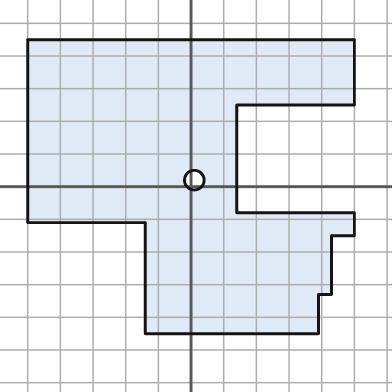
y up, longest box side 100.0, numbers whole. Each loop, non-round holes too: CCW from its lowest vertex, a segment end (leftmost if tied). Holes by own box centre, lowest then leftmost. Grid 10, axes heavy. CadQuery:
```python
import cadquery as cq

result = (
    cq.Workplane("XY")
    .moveTo(-14.0, -45.0)
    .lineTo(39.0, -45.0)
    .lineTo(39.0, -33.0)
    .lineTo(43.0, -33.0)
    .lineTo(43.0, -15.0)
    .lineTo(50.0, -15.0)
    .lineTo(50.0, -8.0)
    .lineTo(14.0, -8.0)
    .lineTo(14.0, 25.0)
    .lineTo(50.0, 25.0)
    .lineTo(50.0, 45.0)
    .lineTo(-50.0, 45.0)
    .lineTo(-50.0, -11.0)
    .lineTo(-14.0, -11.0)
    .close()
    .moveTo(1.0, 2.0)
    .circle(3.0)
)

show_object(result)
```